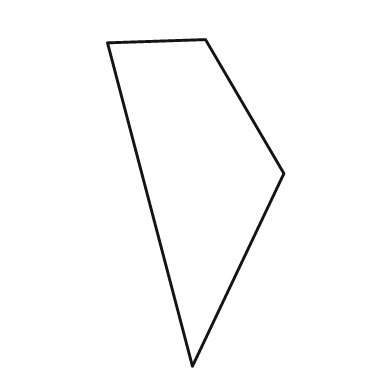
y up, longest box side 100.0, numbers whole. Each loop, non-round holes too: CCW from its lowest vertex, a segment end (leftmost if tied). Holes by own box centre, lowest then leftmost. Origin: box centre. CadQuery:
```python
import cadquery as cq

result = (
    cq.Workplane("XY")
    .moveTo(-1.0, -50.0)
    .lineTo(27.0, 9.0)
    .lineTo(3.0, 50.0)
    .lineTo(-27.0, 49.0)
    .close()
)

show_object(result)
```